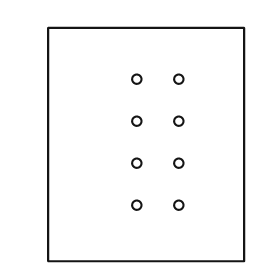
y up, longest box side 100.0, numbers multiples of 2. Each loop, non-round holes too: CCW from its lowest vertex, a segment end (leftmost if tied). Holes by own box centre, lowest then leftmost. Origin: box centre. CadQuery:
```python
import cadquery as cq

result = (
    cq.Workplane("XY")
    .moveTo(-42.0, -50.0)
    .lineTo(42.0, -50.0)
    .lineTo(42.0, 50.0)
    .lineTo(-42.0, 50.0)
    .close()
    .moveTo(-4.0, -26.0)
    .circle(2.0)
    .moveTo(14.0, -26.0)
    .circle(2.0)
    .moveTo(-4.0, -8.0)
    .circle(2.0)
    .moveTo(14.0, -8.0)
    .circle(2.0)
    .moveTo(-4.0, 10.0)
    .circle(2.0)
    .moveTo(14.0, 10.0)
    .circle(2.0)
    .moveTo(-4.0, 28.0)
    .circle(2.0)
    .moveTo(14.0, 28.0)
    .circle(2.0)
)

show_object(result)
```